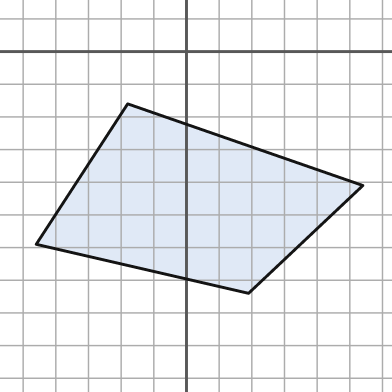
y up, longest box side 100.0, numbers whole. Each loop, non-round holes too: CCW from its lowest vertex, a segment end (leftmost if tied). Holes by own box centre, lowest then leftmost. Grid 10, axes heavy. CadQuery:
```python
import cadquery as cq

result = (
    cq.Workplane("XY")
    .moveTo(19.0, -74.0)
    .lineTo(54.0, -41.0)
    .lineTo(-18.0, -16.0)
    .lineTo(-46.0, -59.0)
    .close()
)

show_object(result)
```